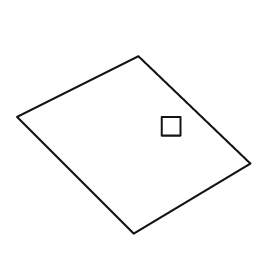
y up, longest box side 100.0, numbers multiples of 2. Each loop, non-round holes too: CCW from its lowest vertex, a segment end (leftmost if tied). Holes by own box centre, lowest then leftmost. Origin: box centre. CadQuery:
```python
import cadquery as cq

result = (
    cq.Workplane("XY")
    .moveTo(0.0, -38.0)
    .lineTo(50.0, -8.0)
    .lineTo(2.0, 38.0)
    .lineTo(-50.0, 12.0)
    .close()
    .moveTo(12.0, 4.0)
    .lineTo(20.0, 4.0)
    .lineTo(20.0, 12.0)
    .lineTo(12.0, 12.0)
    .close()
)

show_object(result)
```